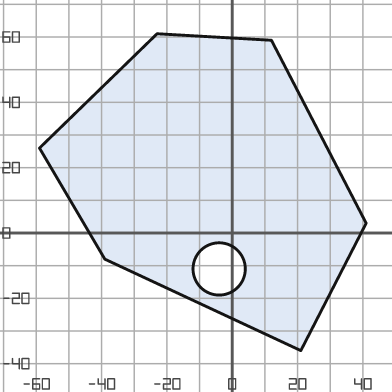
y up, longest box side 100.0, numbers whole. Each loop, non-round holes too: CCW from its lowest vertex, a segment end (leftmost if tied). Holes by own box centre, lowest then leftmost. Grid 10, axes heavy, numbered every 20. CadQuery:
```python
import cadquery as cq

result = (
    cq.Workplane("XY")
    .moveTo(21.0, -36.0)
    .lineTo(41.0, 3.0)
    .lineTo(12.0, 59.0)
    .lineTo(-23.0, 61.0)
    .lineTo(-59.0, 26.0)
    .lineTo(-39.0, -8.0)
    .close()
    .moveTo(-4.0, -11.0)
    .circle(8.0)
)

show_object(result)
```